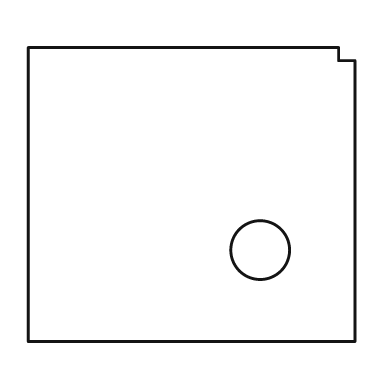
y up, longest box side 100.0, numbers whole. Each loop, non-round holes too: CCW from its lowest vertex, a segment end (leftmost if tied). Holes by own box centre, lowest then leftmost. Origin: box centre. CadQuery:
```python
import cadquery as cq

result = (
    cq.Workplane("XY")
    .moveTo(-50.0, -45.0)
    .lineTo(50.0, -45.0)
    .lineTo(50.0, 41.0)
    .lineTo(45.0, 41.0)
    .lineTo(45.0, 45.0)
    .lineTo(-50.0, 45.0)
    .close()
    .moveTo(21.0, -17.0)
    .circle(9.0)
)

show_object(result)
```